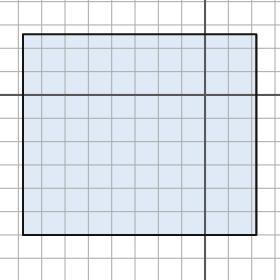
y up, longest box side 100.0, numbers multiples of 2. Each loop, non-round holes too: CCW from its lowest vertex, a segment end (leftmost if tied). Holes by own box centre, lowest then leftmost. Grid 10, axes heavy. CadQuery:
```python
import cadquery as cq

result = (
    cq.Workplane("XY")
    .moveTo(-78.0, -60.0)
    .lineTo(22.0, -60.0)
    .lineTo(22.0, 26.0)
    .lineTo(-78.0, 26.0)
    .close()
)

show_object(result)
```